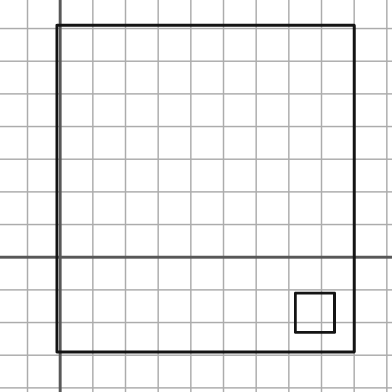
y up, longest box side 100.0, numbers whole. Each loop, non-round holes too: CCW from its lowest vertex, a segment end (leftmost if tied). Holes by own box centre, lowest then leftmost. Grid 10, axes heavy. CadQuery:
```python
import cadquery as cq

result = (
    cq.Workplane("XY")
    .moveTo(-1.0, -29.0)
    .lineTo(90.0, -29.0)
    .lineTo(90.0, 71.0)
    .lineTo(-1.0, 71.0)
    .close()
    .moveTo(72.0, -23.0)
    .lineTo(84.0, -23.0)
    .lineTo(84.0, -11.0)
    .lineTo(72.0, -11.0)
    .close()
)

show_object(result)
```